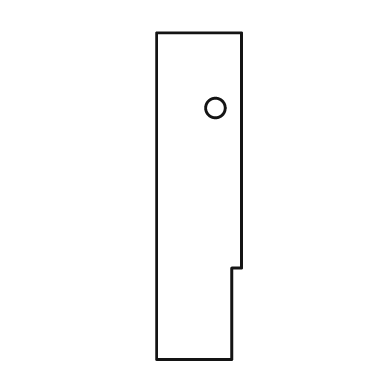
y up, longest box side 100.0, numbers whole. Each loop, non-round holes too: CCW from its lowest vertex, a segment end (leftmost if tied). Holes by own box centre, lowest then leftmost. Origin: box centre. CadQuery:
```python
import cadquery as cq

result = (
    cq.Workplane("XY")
    .moveTo(-13.0, -50.0)
    .lineTo(10.0, -50.0)
    .lineTo(10.0, -22.0)
    .lineTo(13.0, -22.0)
    .lineTo(13.0, 50.0)
    .lineTo(-13.0, 50.0)
    .close()
    .moveTo(5.0, 27.0)
    .circle(3.0)
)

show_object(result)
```